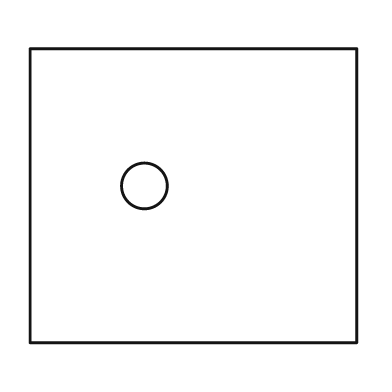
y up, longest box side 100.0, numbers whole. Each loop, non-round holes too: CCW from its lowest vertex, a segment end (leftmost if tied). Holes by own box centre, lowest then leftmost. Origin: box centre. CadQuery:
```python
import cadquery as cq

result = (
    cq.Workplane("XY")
    .moveTo(-50.0, -45.0)
    .lineTo(50.0, -45.0)
    .lineTo(50.0, 45.0)
    .lineTo(-50.0, 45.0)
    .close()
    .moveTo(-15.0, 3.0)
    .circle(7.0)
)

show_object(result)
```